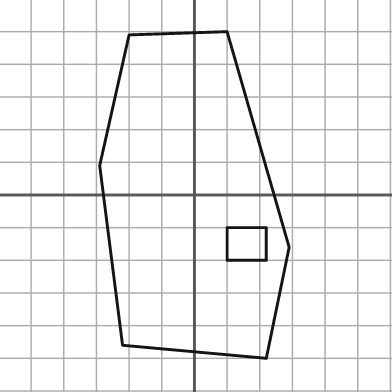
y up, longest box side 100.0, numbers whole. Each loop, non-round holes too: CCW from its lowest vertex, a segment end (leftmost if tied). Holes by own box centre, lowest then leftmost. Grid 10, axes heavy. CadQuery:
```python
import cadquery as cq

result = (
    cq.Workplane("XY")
    .moveTo(22.0, -50.0)
    .lineTo(29.0, -16.0)
    .lineTo(10.0, 50.0)
    .lineTo(-20.0, 49.0)
    .lineTo(-29.0, 9.0)
    .lineTo(-22.0, -46.0)
    .close()
    .moveTo(10.0, -20.0)
    .lineTo(22.0, -20.0)
    .lineTo(22.0, -10.0)
    .lineTo(10.0, -10.0)
    .close()
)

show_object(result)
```